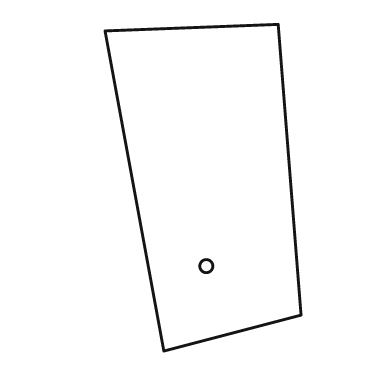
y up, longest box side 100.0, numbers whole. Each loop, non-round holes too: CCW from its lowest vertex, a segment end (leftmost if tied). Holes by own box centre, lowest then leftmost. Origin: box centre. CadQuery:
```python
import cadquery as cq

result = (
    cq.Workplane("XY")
    .moveTo(-12.0, -50.0)
    .lineTo(30.0, -39.0)
    .lineTo(23.0, 50.0)
    .lineTo(-30.0, 48.0)
    .close()
    .moveTo(1.0, -24.0)
    .circle(2.0)
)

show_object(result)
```